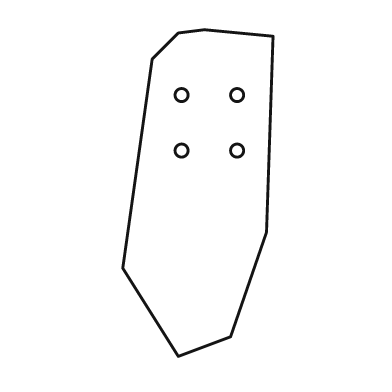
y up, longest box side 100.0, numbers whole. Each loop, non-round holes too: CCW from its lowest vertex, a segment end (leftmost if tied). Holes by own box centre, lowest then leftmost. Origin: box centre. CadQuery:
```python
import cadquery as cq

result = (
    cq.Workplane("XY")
    .moveTo(-6.0, -50.0)
    .lineTo(10.0, -44.0)
    .lineTo(21.0, -12.0)
    .lineTo(23.0, 48.0)
    .lineTo(2.0, 50.0)
    .lineTo(-6.0, 49.0)
    .lineTo(-14.0, 41.0)
    .lineTo(-23.0, -23.0)
    .close()
    .moveTo(-5.0, 13.0)
    .circle(2.0)
    .moveTo(12.0, 13.0)
    .circle(2.0)
    .moveTo(-5.0, 30.0)
    .circle(2.0)
    .moveTo(12.0, 30.0)
    .circle(2.0)
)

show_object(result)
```